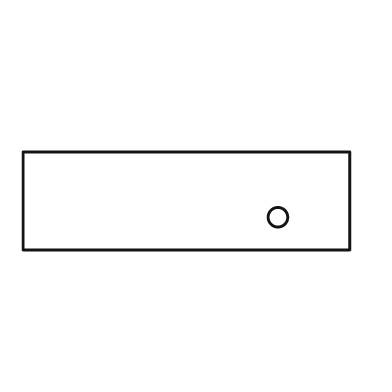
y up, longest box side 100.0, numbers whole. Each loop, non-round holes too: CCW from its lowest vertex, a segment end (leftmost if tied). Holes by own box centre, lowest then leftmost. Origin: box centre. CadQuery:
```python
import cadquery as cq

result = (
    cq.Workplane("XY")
    .moveTo(-50.0, -15.0)
    .lineTo(50.0, -15.0)
    .lineTo(50.0, 15.0)
    .lineTo(-50.0, 15.0)
    .close()
    .moveTo(28.0, -5.0)
    .circle(3.0)
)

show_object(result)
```